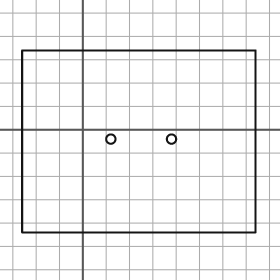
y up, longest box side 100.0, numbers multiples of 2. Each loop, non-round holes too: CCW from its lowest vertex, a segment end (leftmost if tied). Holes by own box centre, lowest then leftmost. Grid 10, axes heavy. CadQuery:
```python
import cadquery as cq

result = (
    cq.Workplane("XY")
    .moveTo(-26.0, -44.0)
    .lineTo(74.0, -44.0)
    .lineTo(74.0, 34.0)
    .lineTo(-26.0, 34.0)
    .close()
    .moveTo(12.0, -4.0)
    .circle(2.0)
    .moveTo(38.0, -4.0)
    .circle(2.0)
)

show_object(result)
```